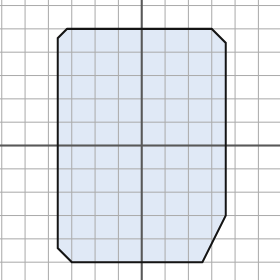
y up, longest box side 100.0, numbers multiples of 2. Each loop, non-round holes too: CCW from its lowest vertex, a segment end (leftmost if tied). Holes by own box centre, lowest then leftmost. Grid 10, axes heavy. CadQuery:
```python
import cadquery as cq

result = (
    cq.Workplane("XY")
    .moveTo(-30.0, -50.0)
    .lineTo(26.0, -50.0)
    .lineTo(36.0, -30.0)
    .lineTo(36.0, 44.0)
    .lineTo(30.0, 50.0)
    .lineTo(-32.0, 50.0)
    .lineTo(-36.0, 46.0)
    .lineTo(-36.0, -44.0)
    .close()
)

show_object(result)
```